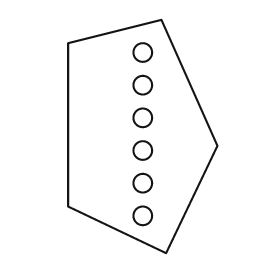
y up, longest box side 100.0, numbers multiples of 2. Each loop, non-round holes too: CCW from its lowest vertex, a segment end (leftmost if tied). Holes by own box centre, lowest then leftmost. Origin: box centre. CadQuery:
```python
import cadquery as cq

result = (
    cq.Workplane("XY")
    .moveTo(10.0, -50.0)
    .lineTo(32.0, -4.0)
    .lineTo(8.0, 50.0)
    .lineTo(-32.0, 40.0)
    .lineTo(-32.0, -30.0)
    .close()
    .moveTo(0.0, -34.0)
    .circle(4.0)
    .moveTo(0.0, -20.0)
    .circle(4.0)
    .moveTo(0.0, -6.0)
    .circle(4.0)
    .moveTo(0.0, 8.0)
    .circle(4.0)
    .moveTo(0.0, 22.0)
    .circle(4.0)
    .moveTo(0.0, 36.0)
    .circle(4.0)
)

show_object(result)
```